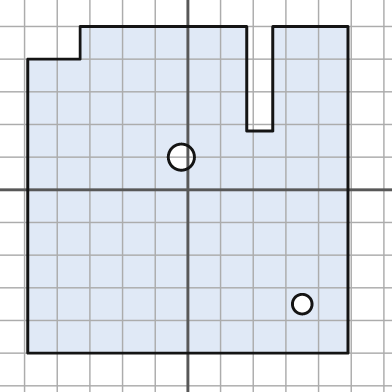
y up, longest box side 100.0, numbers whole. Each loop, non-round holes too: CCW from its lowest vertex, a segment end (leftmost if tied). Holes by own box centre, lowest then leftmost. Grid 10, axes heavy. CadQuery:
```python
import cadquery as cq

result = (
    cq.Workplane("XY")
    .moveTo(-49.0, -50.0)
    .lineTo(49.0, -50.0)
    .lineTo(49.0, 50.0)
    .lineTo(26.0, 50.0)
    .lineTo(26.0, 18.0)
    .lineTo(18.0, 18.0)
    .lineTo(18.0, 50.0)
    .lineTo(-33.0, 50.0)
    .lineTo(-33.0, 40.0)
    .lineTo(-49.0, 40.0)
    .close()
    .moveTo(35.0, -35.0)
    .circle(3.0)
    .moveTo(-2.0, 10.0)
    .circle(4.0)
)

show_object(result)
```